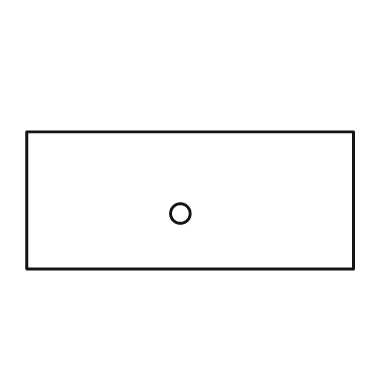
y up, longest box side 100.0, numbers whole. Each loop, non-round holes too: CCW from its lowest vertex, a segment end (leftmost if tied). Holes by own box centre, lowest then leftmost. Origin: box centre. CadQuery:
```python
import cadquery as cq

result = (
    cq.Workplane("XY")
    .moveTo(-50.0, -21.0)
    .lineTo(50.0, -21.0)
    .lineTo(50.0, 21.0)
    .lineTo(-50.0, 21.0)
    .close()
    .moveTo(-3.0, -4.0)
    .circle(3.0)
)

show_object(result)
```